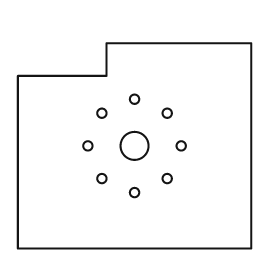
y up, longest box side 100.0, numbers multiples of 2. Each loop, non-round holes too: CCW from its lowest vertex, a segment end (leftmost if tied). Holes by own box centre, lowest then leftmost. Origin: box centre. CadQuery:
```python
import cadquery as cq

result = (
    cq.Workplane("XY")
    .moveTo(-50.0, -44.0)
    .lineTo(50.0, -44.0)
    .lineTo(50.0, 44.0)
    .lineTo(-12.0, 44.0)
    .lineTo(-12.0, 30.0)
    .lineTo(-50.0, 30.0)
    .close()
    .moveTo(0.0, -20.0)
    .circle(2.0)
    .moveTo(-14.0, -14.0)
    .circle(2.0)
    .moveTo(14.0, -14.0)
    .circle(2.0)
    .moveTo(-20.0, 0.0)
    .circle(2.0)
    .moveTo(0.0, 0.0)
    .circle(6.0)
    .moveTo(20.0, 0.0)
    .circle(2.0)
    .moveTo(-14.0, 14.0)
    .circle(2.0)
    .moveTo(14.0, 14.0)
    .circle(2.0)
    .moveTo(0.0, 20.0)
    .circle(2.0)
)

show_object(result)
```